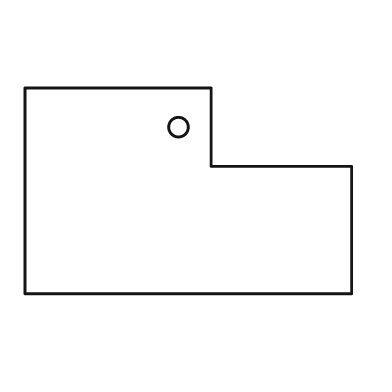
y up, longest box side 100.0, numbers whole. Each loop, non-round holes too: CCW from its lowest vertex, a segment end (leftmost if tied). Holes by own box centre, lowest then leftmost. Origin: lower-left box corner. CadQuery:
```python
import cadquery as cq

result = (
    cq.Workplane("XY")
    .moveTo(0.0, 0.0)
    .lineTo(100.0, 0.0)
    .lineTo(100.0, 39.0)
    .lineTo(57.0, 39.0)
    .lineTo(57.0, 63.0)
    .lineTo(0.0, 63.0)
    .close()
    .moveTo(47.0, 51.0)
    .circle(3.0)
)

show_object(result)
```